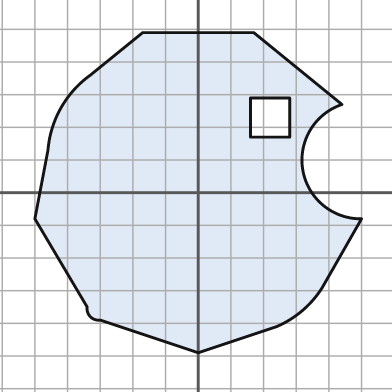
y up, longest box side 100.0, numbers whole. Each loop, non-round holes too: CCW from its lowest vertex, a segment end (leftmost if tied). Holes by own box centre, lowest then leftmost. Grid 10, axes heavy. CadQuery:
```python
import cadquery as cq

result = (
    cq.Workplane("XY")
    .moveTo(0.0, -49.0)
    .lineTo(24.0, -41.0)
    .threePointArc((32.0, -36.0), (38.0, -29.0))
    .lineTo(50.0, -8.0)
    .threePointArc((32.0, 7.0), (44.0, 27.0))
    .lineTo(17.0, 49.0)
    .lineTo(-17.0, 49.0)
    .lineTo(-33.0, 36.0)
    .threePointArc((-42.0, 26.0), (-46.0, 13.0))
    .lineTo(-50.0, -8.0)
    .lineTo(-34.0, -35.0)
    .threePointArc((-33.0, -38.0), (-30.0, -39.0))
    .close()
    .moveTo(16.0, 17.0)
    .lineTo(28.0, 17.0)
    .lineTo(28.0, 29.0)
    .lineTo(16.0, 29.0)
    .close()
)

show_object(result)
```